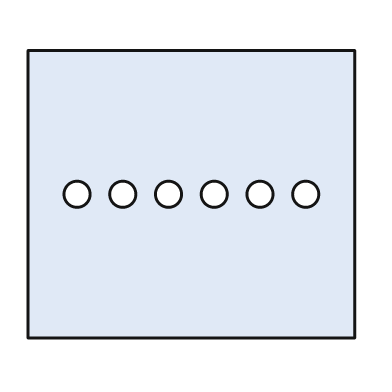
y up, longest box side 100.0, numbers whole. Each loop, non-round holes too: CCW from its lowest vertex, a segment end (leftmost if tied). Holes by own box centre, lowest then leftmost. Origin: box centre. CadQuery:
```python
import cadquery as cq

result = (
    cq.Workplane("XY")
    .moveTo(-50.0, -44.0)
    .lineTo(50.0, -44.0)
    .lineTo(50.0, 44.0)
    .lineTo(-50.0, 44.0)
    .close()
    .moveTo(-35.0, 0.0)
    .circle(4.0)
    .moveTo(-21.0, 0.0)
    .circle(4.0)
    .moveTo(-7.0, 0.0)
    .circle(4.0)
    .moveTo(7.0, 0.0)
    .circle(4.0)
    .moveTo(21.0, 0.0)
    .circle(4.0)
    .moveTo(35.0, 0.0)
    .circle(4.0)
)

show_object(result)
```